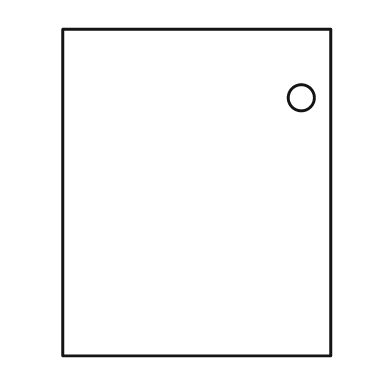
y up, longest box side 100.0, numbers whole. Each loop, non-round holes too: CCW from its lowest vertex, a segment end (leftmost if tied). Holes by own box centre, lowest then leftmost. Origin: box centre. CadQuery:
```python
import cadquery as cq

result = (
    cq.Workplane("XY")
    .moveTo(-41.0, -50.0)
    .lineTo(41.0, -50.0)
    .lineTo(41.0, 50.0)
    .lineTo(-41.0, 50.0)
    .close()
    .moveTo(32.0, 29.0)
    .circle(4.0)
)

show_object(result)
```